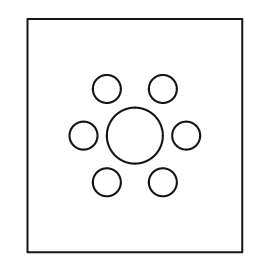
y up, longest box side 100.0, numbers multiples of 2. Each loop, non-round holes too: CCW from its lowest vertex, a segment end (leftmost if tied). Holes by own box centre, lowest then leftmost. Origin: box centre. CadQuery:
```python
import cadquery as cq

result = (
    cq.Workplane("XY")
    .moveTo(-46.0, -50.0)
    .lineTo(46.0, -50.0)
    .lineTo(46.0, 50.0)
    .lineTo(-46.0, 50.0)
    .close()
    .moveTo(-12.0, -20.0)
    .circle(6.0)
    .moveTo(12.0, -20.0)
    .circle(6.0)
    .moveTo(-22.0, 0.0)
    .circle(6.0)
    .moveTo(0.0, 0.0)
    .circle(12.0)
    .moveTo(22.0, 0.0)
    .circle(6.0)
    .moveTo(-12.0, 20.0)
    .circle(6.0)
    .moveTo(12.0, 20.0)
    .circle(6.0)
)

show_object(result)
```